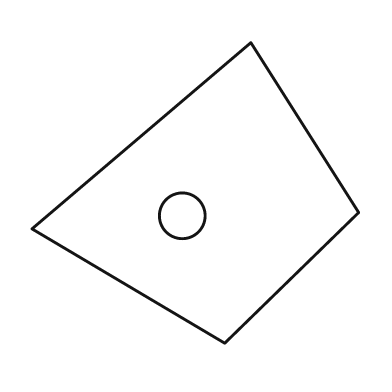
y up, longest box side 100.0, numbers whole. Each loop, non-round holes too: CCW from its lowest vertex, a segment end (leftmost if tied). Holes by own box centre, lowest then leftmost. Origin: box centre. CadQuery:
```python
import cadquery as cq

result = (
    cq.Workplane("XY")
    .moveTo(9.0, -46.0)
    .lineTo(50.0, -6.0)
    .lineTo(17.0, 46.0)
    .lineTo(-50.0, -11.0)
    .close()
    .moveTo(-4.0, -7.0)
    .circle(7.0)
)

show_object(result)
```